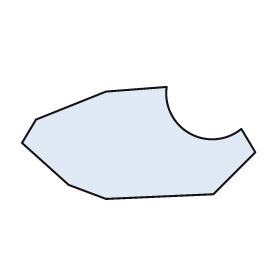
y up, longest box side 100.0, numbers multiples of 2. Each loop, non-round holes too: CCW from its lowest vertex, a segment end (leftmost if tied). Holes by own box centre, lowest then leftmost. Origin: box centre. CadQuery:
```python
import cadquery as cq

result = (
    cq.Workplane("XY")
    .moveTo(-14.0, -24.0)
    .lineTo(32.0, -22.0)
    .lineTo(50.0, -4.0)
    .lineTo(44.0, 6.0)
    .threePointArc((22.0, 4.0), (12.0, 24.0))
    .lineTo(-14.0, 22.0)
    .lineTo(-44.0, 10.0)
    .lineTo(-50.0, 0.0)
    .lineTo(-30.0, -18.0)
    .close()
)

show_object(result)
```